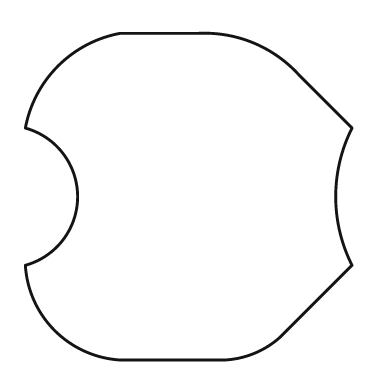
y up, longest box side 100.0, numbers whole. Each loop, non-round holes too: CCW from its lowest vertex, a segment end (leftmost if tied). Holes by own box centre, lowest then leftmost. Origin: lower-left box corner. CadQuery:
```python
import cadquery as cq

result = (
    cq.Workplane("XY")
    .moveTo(29.0, 0.0)
    .lineTo(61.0, 0.0)
    .threePointArc((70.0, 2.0), (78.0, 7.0))
    .lineTo(100.0, 29.0)
    .threePointArc((95.0, 50.0), (100.0, 71.0))
    .lineTo(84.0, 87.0)
    .threePointArc((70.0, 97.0), (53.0, 100.0))
    .lineTo(29.0, 100.0)
    .threePointArc((10.0, 90.0), (0.0, 71.0))
    .threePointArc((16.0, 50.0), (0.0, 29.0))
    .threePointArc((9.0, 9.0), (29.0, 0.0))
    .close()
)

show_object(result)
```